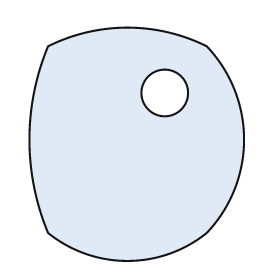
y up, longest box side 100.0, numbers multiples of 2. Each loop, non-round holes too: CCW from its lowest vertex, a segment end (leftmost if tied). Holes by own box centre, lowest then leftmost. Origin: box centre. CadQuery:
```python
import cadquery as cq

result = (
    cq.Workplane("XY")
    .moveTo(-38.0, -38.0)
    .threePointArc((-4.0, -50.0), (30.0, -38.0))
    .threePointArc((46.0, 2.0), (30.0, 42.0))
    .threePointArc((-4.0, 50.0), (-38.0, 42.0))
    .threePointArc((-46.0, 2.0), (-38.0, -38.0))
    .close()
    .moveTo(12.0, 22.0)
    .circle(10.0)
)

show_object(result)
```